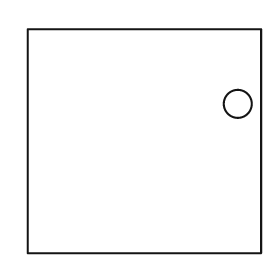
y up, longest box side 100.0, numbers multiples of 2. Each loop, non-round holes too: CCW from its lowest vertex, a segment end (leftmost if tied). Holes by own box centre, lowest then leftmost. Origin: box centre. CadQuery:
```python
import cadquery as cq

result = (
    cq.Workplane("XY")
    .moveTo(-50.0, -48.0)
    .lineTo(50.0, -48.0)
    .lineTo(50.0, 48.0)
    .lineTo(-50.0, 48.0)
    .close()
    .moveTo(40.0, 16.0)
    .circle(6.0)
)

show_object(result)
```